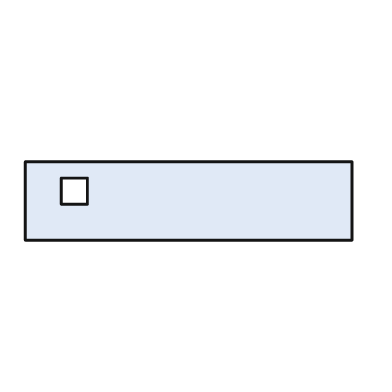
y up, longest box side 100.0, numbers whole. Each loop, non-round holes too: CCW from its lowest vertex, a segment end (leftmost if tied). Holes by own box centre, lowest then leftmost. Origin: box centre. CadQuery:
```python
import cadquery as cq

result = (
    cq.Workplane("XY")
    .moveTo(-50.0, -12.0)
    .lineTo(50.0, -12.0)
    .lineTo(50.0, 12.0)
    .lineTo(-50.0, 12.0)
    .close()
    .moveTo(-39.0, -1.0)
    .lineTo(-31.0, -1.0)
    .lineTo(-31.0, 7.0)
    .lineTo(-39.0, 7.0)
    .close()
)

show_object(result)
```